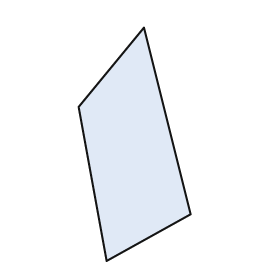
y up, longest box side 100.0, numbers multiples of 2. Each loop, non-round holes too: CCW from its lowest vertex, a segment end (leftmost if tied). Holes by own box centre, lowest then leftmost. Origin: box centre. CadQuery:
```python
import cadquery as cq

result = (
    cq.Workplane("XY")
    .moveTo(-12.0, -50.0)
    .lineTo(24.0, -30.0)
    .lineTo(4.0, 50.0)
    .lineTo(-24.0, 16.0)
    .close()
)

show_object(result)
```